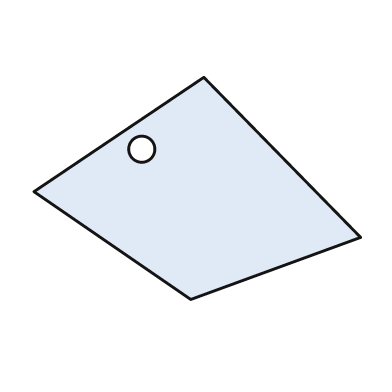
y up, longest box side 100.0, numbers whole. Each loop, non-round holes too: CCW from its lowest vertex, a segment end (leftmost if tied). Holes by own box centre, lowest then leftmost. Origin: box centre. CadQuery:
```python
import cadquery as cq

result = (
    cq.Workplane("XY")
    .moveTo(-2.0, -34.0)
    .lineTo(50.0, -15.0)
    .lineTo(2.0, 34.0)
    .lineTo(-50.0, -1.0)
    .close()
    .moveTo(-17.0, 12.0)
    .circle(4.0)
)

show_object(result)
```